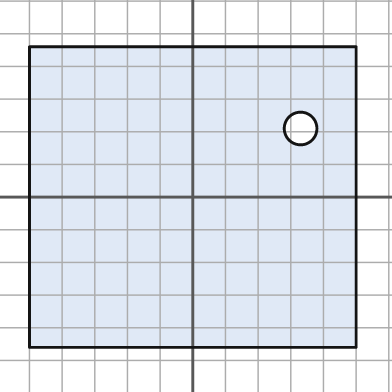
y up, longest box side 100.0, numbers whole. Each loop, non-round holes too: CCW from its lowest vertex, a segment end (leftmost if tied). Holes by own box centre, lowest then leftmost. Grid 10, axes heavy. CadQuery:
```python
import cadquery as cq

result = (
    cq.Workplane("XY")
    .moveTo(-50.0, -46.0)
    .lineTo(50.0, -46.0)
    .lineTo(50.0, 46.0)
    .lineTo(-50.0, 46.0)
    .close()
    .moveTo(33.0, 21.0)
    .circle(5.0)
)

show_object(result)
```